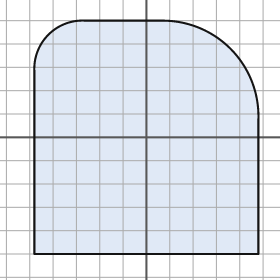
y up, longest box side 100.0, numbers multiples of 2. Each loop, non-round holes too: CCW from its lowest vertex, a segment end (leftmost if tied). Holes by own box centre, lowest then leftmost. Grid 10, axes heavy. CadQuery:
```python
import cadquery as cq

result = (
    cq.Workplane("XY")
    .moveTo(-48.0, -50.0)
    .lineTo(48.0, -50.0)
    .lineTo(48.0, 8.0)
    .threePointArc((36.0, 38.0), (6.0, 50.0))
    .lineTo(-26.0, 50.0)
    .threePointArc((-42.0, 44.0), (-48.0, 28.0))
    .close()
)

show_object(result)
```